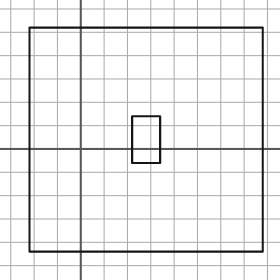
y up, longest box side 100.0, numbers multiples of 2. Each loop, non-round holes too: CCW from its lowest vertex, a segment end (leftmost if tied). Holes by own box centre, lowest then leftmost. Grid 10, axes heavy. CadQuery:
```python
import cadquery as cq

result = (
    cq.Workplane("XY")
    .moveTo(-22.0, -44.0)
    .lineTo(78.0, -44.0)
    .lineTo(78.0, 52.0)
    .lineTo(-22.0, 52.0)
    .close()
    .moveTo(22.0, -6.0)
    .lineTo(34.0, -6.0)
    .lineTo(34.0, 14.0)
    .lineTo(22.0, 14.0)
    .close()
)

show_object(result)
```